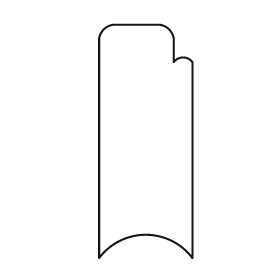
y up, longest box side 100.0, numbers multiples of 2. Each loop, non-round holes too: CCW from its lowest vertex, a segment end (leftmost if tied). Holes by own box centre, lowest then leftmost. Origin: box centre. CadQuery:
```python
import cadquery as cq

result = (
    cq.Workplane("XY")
    .moveTo(-20.0, -50.0)
    .threePointArc((0.0, -40.0), (20.0, -50.0))
    .lineTo(20.0, 34.0)
    .threePointArc((16.0, 36.0), (12.0, 34.0))
    .lineTo(12.0, 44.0)
    .threePointArc((10.0, 48.0), (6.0, 50.0))
    .lineTo(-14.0, 50.0)
    .threePointArc((-18.0, 48.0), (-20.0, 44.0))
    .close()
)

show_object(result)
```